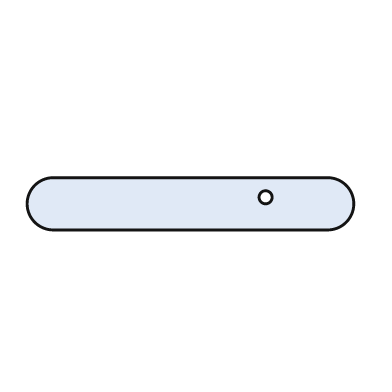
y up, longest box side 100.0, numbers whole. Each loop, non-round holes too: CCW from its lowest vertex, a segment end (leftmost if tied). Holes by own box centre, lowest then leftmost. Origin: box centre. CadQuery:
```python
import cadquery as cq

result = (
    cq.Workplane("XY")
    .moveTo(-42.0, -8.0)
    .lineTo(42.0, -8.0)
    .threePointArc((50.0, 0.0), (42.0, 8.0))
    .lineTo(-42.0, 8.0)
    .threePointArc((-50.0, 0.0), (-42.0, -8.0))
    .close()
    .moveTo(23.0, 2.0)
    .circle(2.0)
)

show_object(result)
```